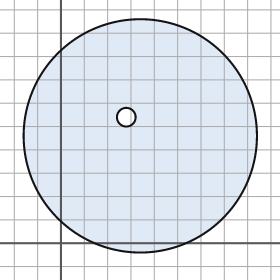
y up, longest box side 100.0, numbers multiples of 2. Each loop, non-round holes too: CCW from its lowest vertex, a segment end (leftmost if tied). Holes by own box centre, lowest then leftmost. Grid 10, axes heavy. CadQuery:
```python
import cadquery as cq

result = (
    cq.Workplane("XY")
    .moveTo(34.0, 46.0)
    .circle(50.0)
    .moveTo(28.0, 54.0)
    .circle(4.0)
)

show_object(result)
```